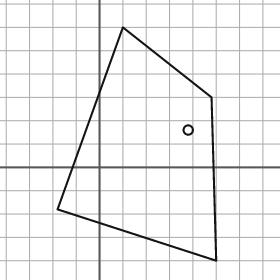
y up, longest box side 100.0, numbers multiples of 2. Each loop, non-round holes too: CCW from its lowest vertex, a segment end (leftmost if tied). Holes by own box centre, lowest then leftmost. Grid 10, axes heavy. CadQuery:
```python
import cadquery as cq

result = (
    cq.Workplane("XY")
    .moveTo(50.0, -40.0)
    .lineTo(48.0, 30.0)
    .lineTo(10.0, 60.0)
    .lineTo(-18.0, -18.0)
    .close()
    .moveTo(38.0, 16.0)
    .circle(2.0)
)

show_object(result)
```